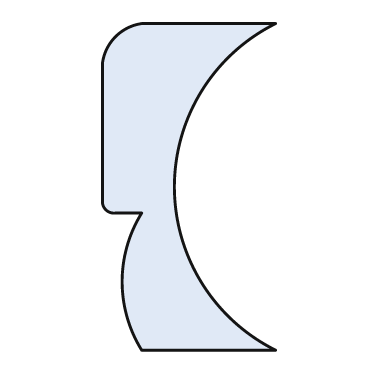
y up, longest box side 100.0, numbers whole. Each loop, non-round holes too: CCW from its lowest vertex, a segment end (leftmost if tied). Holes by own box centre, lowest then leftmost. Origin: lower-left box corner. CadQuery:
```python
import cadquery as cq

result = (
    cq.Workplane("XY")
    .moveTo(12.0, 0.0)
    .lineTo(53.0, 0.0)
    .threePointArc((22.0, 50.0), (53.0, 100.0))
    .lineTo(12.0, 100.0)
    .threePointArc((4.0, 96.0), (0.0, 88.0))
    .lineTo(0.0, 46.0)
    .threePointArc((1.0, 43.0), (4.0, 42.0))
    .lineTo(12.0, 42.0)
    .threePointArc((6.0, 21.0), (12.0, 0.0))
    .close()
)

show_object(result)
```